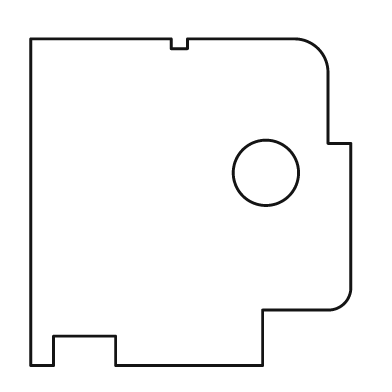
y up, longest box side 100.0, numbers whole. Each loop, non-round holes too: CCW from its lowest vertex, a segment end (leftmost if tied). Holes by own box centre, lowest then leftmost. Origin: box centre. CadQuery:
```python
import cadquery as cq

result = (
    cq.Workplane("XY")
    .moveTo(-49.0, -50.0)
    .lineTo(-42.0, -50.0)
    .lineTo(-42.0, -41.0)
    .lineTo(-23.0, -41.0)
    .lineTo(-23.0, -50.0)
    .lineTo(22.0, -50.0)
    .lineTo(22.0, -33.0)
    .lineTo(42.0, -33.0)
    .threePointArc((47.0, -31.0), (49.0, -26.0))
    .lineTo(49.0, 18.0)
    .lineTo(42.0, 18.0)
    .lineTo(42.0, 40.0)
    .threePointArc((39.0, 47.0), (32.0, 50.0))
    .lineTo(-1.0, 50.0)
    .lineTo(-1.0, 47.0)
    .lineTo(-6.0, 47.0)
    .lineTo(-6.0, 50.0)
    .lineTo(-49.0, 50.0)
    .close()
    .moveTo(23.0, 9.0)
    .circle(10.0)
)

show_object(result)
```